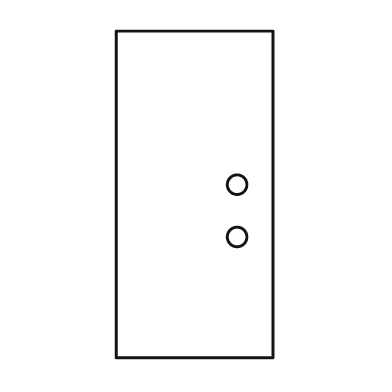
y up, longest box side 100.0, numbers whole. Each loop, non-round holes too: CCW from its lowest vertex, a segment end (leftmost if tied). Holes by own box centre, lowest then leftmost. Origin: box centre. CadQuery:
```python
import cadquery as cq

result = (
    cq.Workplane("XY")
    .moveTo(-24.0, -50.0)
    .lineTo(24.0, -50.0)
    .lineTo(24.0, 50.0)
    .lineTo(-24.0, 50.0)
    .close()
    .moveTo(13.0, -13.0)
    .circle(3.0)
    .moveTo(13.0, 3.0)
    .circle(3.0)
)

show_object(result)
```